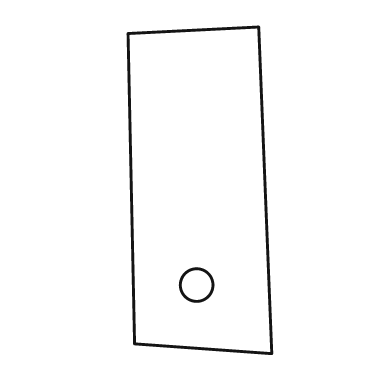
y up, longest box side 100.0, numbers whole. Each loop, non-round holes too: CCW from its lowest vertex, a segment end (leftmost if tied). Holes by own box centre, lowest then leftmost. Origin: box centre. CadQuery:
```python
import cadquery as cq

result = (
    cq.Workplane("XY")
    .moveTo(22.0, -50.0)
    .lineTo(18.0, 50.0)
    .lineTo(-22.0, 48.0)
    .lineTo(-20.0, -47.0)
    .close()
    .moveTo(-1.0, -29.0)
    .circle(5.0)
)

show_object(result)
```